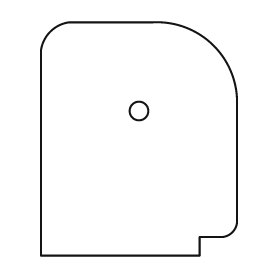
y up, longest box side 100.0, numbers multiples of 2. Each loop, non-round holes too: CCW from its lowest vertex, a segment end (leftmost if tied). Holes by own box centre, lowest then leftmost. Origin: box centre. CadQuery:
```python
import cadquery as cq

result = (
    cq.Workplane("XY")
    .moveTo(-42.0, -50.0)
    .lineTo(26.0, -50.0)
    .lineTo(26.0, -42.0)
    .lineTo(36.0, -42.0)
    .threePointArc((40.0, -40.0), (42.0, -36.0))
    .lineTo(42.0, 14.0)
    .threePointArc((32.0, 40.0), (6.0, 50.0))
    .lineTo(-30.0, 50.0)
    .threePointArc((-38.0, 46.0), (-42.0, 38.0))
    .close()
    .moveTo(0.0, 12.0)
    .circle(4.0)
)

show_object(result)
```